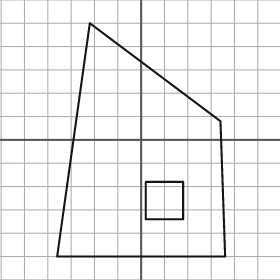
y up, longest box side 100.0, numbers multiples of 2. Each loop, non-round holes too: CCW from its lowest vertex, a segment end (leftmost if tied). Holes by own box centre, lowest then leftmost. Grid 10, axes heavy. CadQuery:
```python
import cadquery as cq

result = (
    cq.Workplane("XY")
    .moveTo(-36.0, -50.0)
    .lineTo(36.0, -50.0)
    .lineTo(34.0, 8.0)
    .lineTo(-22.0, 50.0)
    .close()
    .moveTo(2.0, -34.0)
    .lineTo(18.0, -34.0)
    .lineTo(18.0, -18.0)
    .lineTo(2.0, -18.0)
    .close()
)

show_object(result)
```